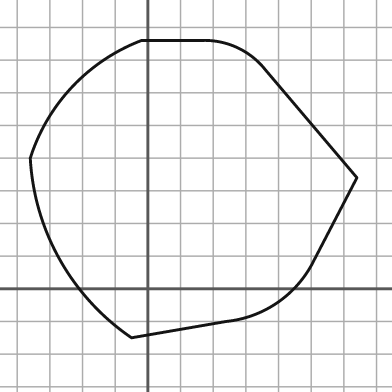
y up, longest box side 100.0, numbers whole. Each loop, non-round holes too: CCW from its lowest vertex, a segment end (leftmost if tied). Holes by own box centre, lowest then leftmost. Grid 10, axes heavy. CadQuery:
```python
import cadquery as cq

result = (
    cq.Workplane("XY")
    .moveTo(-5.0, -15.0)
    .lineTo(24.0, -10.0)
    .threePointArc((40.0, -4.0), (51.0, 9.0))
    .lineTo(64.0, 34.0)
    .lineTo(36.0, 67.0)
    .threePointArc((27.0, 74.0), (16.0, 76.0))
    .lineTo(-2.0, 76.0)
    .threePointArc((-23.0, 62.0), (-36.0, 40.0))
    .threePointArc((-27.0, 9.0), (-5.0, -15.0))
    .close()
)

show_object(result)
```